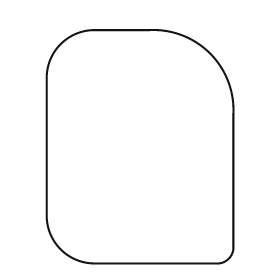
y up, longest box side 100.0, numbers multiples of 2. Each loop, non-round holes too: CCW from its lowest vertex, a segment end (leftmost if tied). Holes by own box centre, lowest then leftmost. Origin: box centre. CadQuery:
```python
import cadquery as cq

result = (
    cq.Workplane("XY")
    .moveTo(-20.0, -50.0)
    .lineTo(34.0, -50.0)
    .threePointArc((38.0, -48.0), (40.0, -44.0))
    .lineTo(40.0, 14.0)
    .threePointArc((30.0, 40.0), (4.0, 50.0))
    .lineTo(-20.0, 50.0)
    .threePointArc((-34.0, 44.0), (-40.0, 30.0))
    .lineTo(-40.0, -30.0)
    .threePointArc((-34.0, -44.0), (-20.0, -50.0))
    .close()
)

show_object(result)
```